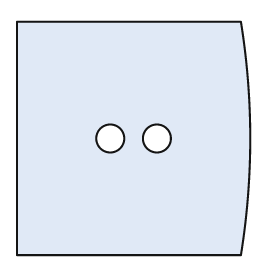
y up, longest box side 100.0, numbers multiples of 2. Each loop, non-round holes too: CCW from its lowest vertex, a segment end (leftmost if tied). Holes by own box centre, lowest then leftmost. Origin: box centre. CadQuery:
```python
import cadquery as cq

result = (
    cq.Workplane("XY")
    .moveTo(-50.0, -50.0)
    .lineTo(46.0, -50.0)
    .threePointArc((50.0, 0.0), (46.0, 50.0))
    .lineTo(-50.0, 50.0)
    .close()
    .moveTo(-10.0, 0.0)
    .circle(6.0)
    .moveTo(10.0, 0.0)
    .circle(6.0)
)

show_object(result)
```